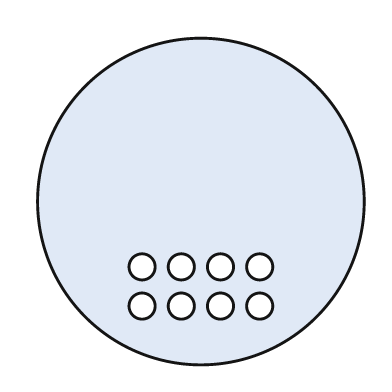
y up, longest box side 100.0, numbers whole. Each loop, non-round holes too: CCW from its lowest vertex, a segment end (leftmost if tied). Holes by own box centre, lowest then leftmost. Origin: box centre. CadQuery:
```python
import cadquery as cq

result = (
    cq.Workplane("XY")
    .moveTo(0.0, 0.0)
    .circle(50.0)
    .moveTo(-18.0, -32.0)
    .circle(4.0)
    .moveTo(-6.0, -32.0)
    .circle(4.0)
    .moveTo(6.0, -32.0)
    .circle(4.0)
    .moveTo(18.0, -32.0)
    .circle(4.0)
    .moveTo(-18.0, -20.0)
    .circle(4.0)
    .moveTo(-6.0, -20.0)
    .circle(4.0)
    .moveTo(6.0, -20.0)
    .circle(4.0)
    .moveTo(18.0, -20.0)
    .circle(4.0)
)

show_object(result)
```